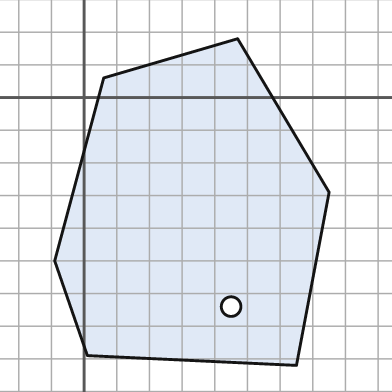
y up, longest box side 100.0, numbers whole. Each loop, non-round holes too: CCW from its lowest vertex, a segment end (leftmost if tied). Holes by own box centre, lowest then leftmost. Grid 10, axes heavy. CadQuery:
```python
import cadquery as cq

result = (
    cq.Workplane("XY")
    .moveTo(65.0, -82.0)
    .lineTo(75.0, -29.0)
    .lineTo(47.0, 18.0)
    .lineTo(6.0, 6.0)
    .lineTo(-9.0, -50.0)
    .lineTo(1.0, -79.0)
    .close()
    .moveTo(45.0, -64.0)
    .circle(3.0)
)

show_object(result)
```